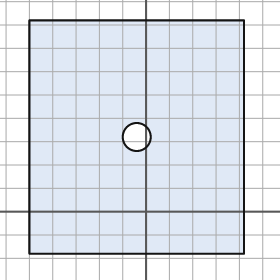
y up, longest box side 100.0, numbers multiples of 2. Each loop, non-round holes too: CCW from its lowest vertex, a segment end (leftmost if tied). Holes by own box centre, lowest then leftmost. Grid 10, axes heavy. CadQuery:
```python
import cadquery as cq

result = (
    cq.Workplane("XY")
    .moveTo(-50.0, -18.0)
    .lineTo(42.0, -18.0)
    .lineTo(42.0, 82.0)
    .lineTo(-50.0, 82.0)
    .close()
    .moveTo(-4.0, 32.0)
    .circle(6.0)
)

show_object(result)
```